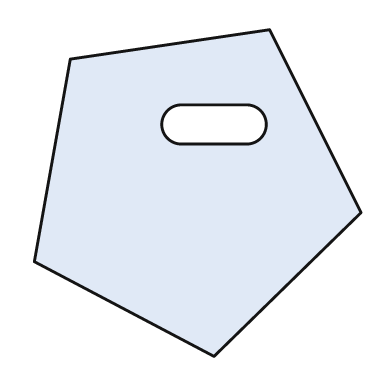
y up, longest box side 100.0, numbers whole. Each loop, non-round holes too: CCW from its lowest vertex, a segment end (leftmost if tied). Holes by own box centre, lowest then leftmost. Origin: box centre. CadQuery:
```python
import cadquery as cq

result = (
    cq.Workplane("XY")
    .moveTo(5.0, -50.0)
    .lineTo(50.0, -6.0)
    .lineTo(22.0, 50.0)
    .lineTo(-39.0, 41.0)
    .lineTo(-50.0, -21.0)
    .close()
    .moveTo(-5.0, 15.0)
    .lineTo(15.0, 15.0)
    .threePointArc((21.0, 21.0), (15.0, 27.0))
    .lineTo(-5.0, 27.0)
    .threePointArc((-11.0, 21.0), (-5.0, 15.0))
    .close()
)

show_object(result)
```